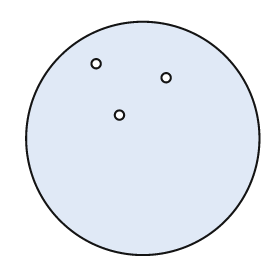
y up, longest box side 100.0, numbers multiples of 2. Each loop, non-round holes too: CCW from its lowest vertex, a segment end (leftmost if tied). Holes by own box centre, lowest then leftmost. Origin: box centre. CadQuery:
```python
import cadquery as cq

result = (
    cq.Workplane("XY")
    .moveTo(0.0, 0.0)
    .circle(50.0)
    .moveTo(-10.0, 10.0)
    .circle(2.0)
    .moveTo(10.0, 26.0)
    .circle(2.0)
    .moveTo(-20.0, 32.0)
    .circle(2.0)
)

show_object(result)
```